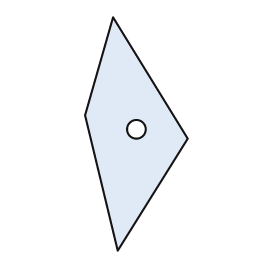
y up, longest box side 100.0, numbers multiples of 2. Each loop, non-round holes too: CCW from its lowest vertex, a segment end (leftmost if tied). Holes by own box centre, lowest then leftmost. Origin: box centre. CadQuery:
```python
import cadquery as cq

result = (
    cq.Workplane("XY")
    .moveTo(-8.0, -50.0)
    .lineTo(22.0, -2.0)
    .lineTo(-10.0, 50.0)
    .lineTo(-22.0, 8.0)
    .close()
    .moveTo(0.0, 2.0)
    .circle(4.0)
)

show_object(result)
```